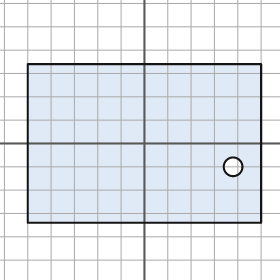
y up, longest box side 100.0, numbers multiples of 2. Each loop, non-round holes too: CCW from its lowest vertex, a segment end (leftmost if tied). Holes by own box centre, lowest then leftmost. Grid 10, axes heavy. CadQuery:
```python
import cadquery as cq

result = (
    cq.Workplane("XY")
    .moveTo(-50.0, -34.0)
    .lineTo(50.0, -34.0)
    .lineTo(50.0, 34.0)
    .lineTo(-50.0, 34.0)
    .close()
    .moveTo(38.0, -10.0)
    .circle(4.0)
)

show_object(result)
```